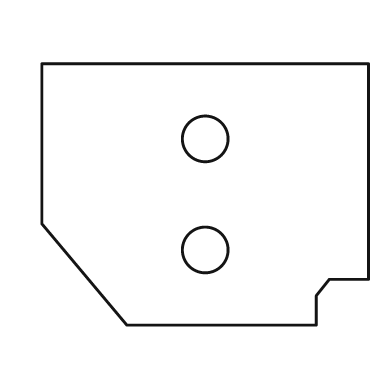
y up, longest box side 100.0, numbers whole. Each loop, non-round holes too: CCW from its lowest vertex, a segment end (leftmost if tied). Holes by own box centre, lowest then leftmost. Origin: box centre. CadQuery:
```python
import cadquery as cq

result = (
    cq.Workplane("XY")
    .moveTo(-24.0, -40.0)
    .lineTo(34.0, -40.0)
    .lineTo(34.0, -31.0)
    .lineTo(38.0, -26.0)
    .lineTo(50.0, -26.0)
    .lineTo(50.0, 40.0)
    .lineTo(-50.0, 40.0)
    .lineTo(-50.0, -9.0)
    .close()
    .moveTo(0.0, -17.0)
    .circle(7.0)
    .moveTo(0.0, 17.0)
    .circle(7.0)
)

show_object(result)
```